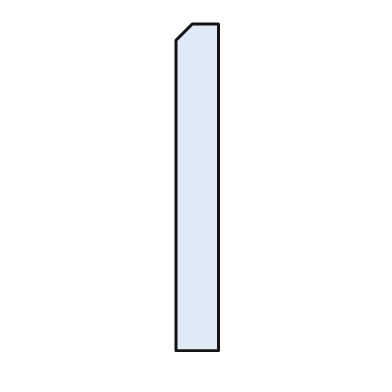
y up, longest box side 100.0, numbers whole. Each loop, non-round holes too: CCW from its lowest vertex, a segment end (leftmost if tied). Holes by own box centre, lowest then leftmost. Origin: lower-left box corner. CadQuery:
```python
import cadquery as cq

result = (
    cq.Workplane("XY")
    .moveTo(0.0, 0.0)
    .lineTo(13.0, 0.0)
    .lineTo(13.0, 100.0)
    .lineTo(5.0, 100.0)
    .lineTo(0.0, 95.0)
    .close()
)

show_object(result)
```